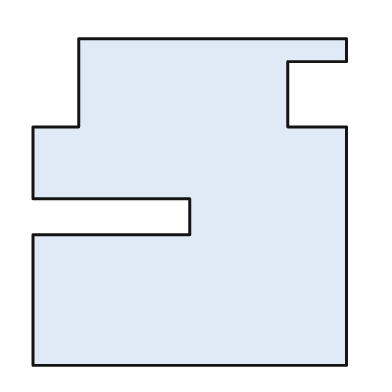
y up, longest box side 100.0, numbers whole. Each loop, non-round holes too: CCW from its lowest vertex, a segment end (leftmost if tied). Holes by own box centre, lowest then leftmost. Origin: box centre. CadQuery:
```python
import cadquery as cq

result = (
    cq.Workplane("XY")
    .moveTo(-48.0, -50.0)
    .lineTo(48.0, -50.0)
    .lineTo(48.0, 23.0)
    .lineTo(30.0, 23.0)
    .lineTo(30.0, 43.0)
    .lineTo(48.0, 43.0)
    .lineTo(48.0, 50.0)
    .lineTo(-34.0, 50.0)
    .lineTo(-34.0, 23.0)
    .lineTo(-48.0, 23.0)
    .lineTo(-48.0, 1.0)
    .lineTo(0.0, 1.0)
    .lineTo(0.0, -10.0)
    .lineTo(-48.0, -10.0)
    .close()
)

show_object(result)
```